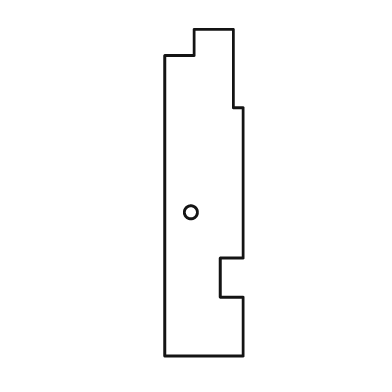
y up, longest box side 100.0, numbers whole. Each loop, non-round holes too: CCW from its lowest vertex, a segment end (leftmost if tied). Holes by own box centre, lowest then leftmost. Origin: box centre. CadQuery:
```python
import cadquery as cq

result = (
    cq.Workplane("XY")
    .moveTo(-12.0, -50.0)
    .lineTo(12.0, -50.0)
    .lineTo(12.0, -32.0)
    .lineTo(5.0, -32.0)
    .lineTo(5.0, -20.0)
    .lineTo(12.0, -20.0)
    .lineTo(12.0, 26.0)
    .lineTo(9.0, 26.0)
    .lineTo(9.0, 50.0)
    .lineTo(-3.0, 50.0)
    .lineTo(-3.0, 42.0)
    .lineTo(-12.0, 42.0)
    .close()
    .moveTo(-4.0, -6.0)
    .circle(2.0)
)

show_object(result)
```